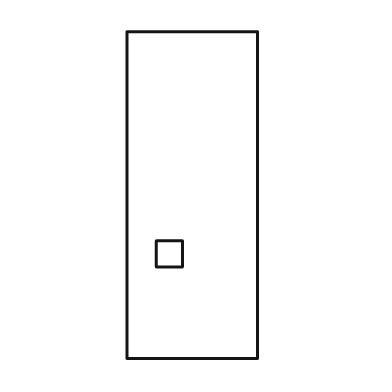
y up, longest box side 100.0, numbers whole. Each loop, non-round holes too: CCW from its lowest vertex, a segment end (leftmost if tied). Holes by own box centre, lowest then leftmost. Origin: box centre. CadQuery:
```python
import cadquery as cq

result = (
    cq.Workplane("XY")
    .moveTo(-20.0, -50.0)
    .lineTo(20.0, -50.0)
    .lineTo(20.0, 50.0)
    .lineTo(-20.0, 50.0)
    .close()
    .moveTo(-11.0, -22.0)
    .lineTo(-3.0, -22.0)
    .lineTo(-3.0, -14.0)
    .lineTo(-11.0, -14.0)
    .close()
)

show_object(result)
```